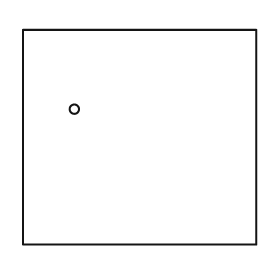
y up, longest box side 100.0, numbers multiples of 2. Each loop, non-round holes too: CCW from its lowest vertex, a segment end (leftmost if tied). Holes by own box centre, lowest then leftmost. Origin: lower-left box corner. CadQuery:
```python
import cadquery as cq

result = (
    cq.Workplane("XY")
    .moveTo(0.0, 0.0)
    .lineTo(100.0, 0.0)
    .lineTo(100.0, 92.0)
    .lineTo(0.0, 92.0)
    .close()
    .moveTo(22.0, 58.0)
    .circle(2.0)
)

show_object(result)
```